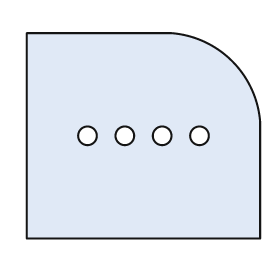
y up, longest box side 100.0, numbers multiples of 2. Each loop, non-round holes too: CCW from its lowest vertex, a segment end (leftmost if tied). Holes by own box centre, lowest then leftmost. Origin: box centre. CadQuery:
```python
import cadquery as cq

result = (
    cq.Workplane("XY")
    .moveTo(-50.0, -44.0)
    .lineTo(50.0, -44.0)
    .lineTo(50.0, 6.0)
    .threePointArc((38.0, 32.0), (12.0, 44.0))
    .lineTo(-50.0, 44.0)
    .close()
    .moveTo(-24.0, 0.0)
    .circle(4.0)
    .moveTo(-8.0, 0.0)
    .circle(4.0)
    .moveTo(8.0, 0.0)
    .circle(4.0)
    .moveTo(24.0, 0.0)
    .circle(4.0)
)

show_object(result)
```